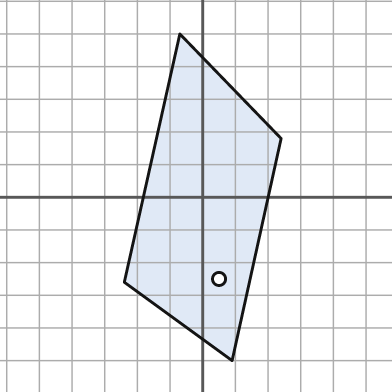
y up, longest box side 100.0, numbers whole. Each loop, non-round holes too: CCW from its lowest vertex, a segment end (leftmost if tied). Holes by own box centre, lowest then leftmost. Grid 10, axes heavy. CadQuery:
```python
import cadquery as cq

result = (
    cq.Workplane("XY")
    .moveTo(9.0, -50.0)
    .lineTo(24.0, 18.0)
    .lineTo(-7.0, 50.0)
    .lineTo(-24.0, -26.0)
    .close()
    .moveTo(5.0, -25.0)
    .circle(2.0)
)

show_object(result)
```